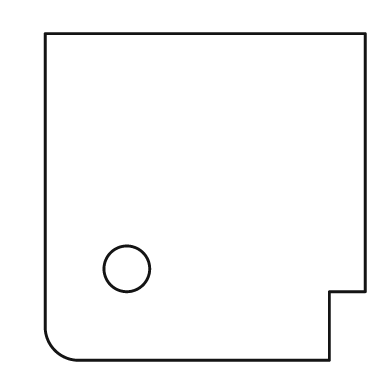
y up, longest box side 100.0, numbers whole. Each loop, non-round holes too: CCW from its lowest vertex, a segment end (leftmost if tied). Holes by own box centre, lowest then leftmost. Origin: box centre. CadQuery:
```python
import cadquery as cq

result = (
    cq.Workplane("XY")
    .moveTo(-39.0, -50.0)
    .lineTo(38.0, -50.0)
    .lineTo(38.0, -29.0)
    .lineTo(49.0, -29.0)
    .lineTo(49.0, 50.0)
    .lineTo(-49.0, 50.0)
    .lineTo(-49.0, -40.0)
    .threePointArc((-46.0, -47.0), (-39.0, -50.0))
    .close()
    .moveTo(-24.0, -22.0)
    .circle(7.0)
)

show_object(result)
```